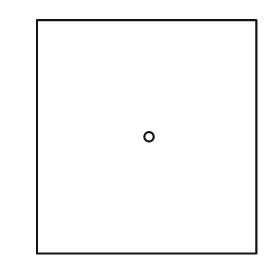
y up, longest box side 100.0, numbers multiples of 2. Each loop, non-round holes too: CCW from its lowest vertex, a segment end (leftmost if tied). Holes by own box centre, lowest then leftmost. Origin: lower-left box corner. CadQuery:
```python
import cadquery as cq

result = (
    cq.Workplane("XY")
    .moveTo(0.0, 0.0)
    .lineTo(94.0, 0.0)
    .lineTo(94.0, 100.0)
    .lineTo(0.0, 100.0)
    .close()
    .moveTo(48.0, 50.0)
    .circle(2.0)
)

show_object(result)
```